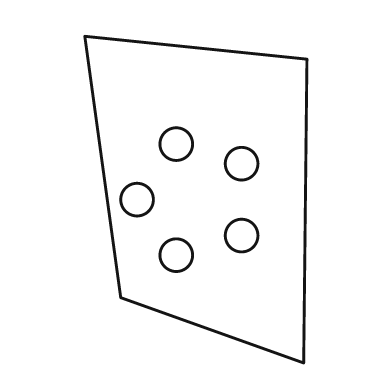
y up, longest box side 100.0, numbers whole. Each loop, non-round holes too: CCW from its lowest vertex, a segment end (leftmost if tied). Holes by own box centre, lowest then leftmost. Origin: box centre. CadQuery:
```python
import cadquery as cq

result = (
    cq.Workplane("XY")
    .moveTo(33.0, -50.0)
    .lineTo(34.0, 43.0)
    .lineTo(-34.0, 50.0)
    .lineTo(-23.0, -30.0)
    .close()
    .moveTo(-6.0, -17.0)
    .circle(5.0)
    .moveTo(14.0, -11.0)
    .circle(5.0)
    .moveTo(-18.0, 0.0)
    .circle(5.0)
    .moveTo(14.0, 11.0)
    .circle(5.0)
    .moveTo(-6.0, 17.0)
    .circle(5.0)
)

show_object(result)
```